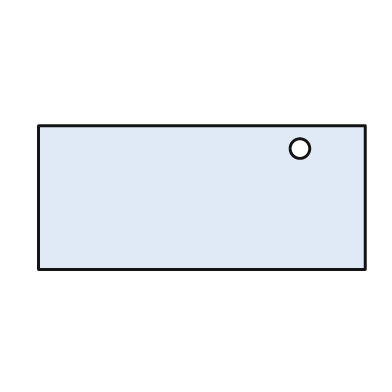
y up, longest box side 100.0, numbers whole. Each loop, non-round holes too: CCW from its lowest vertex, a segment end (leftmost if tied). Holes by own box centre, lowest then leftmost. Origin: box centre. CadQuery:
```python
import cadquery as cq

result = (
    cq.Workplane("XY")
    .moveTo(-50.0, -22.0)
    .lineTo(50.0, -22.0)
    .lineTo(50.0, 22.0)
    .lineTo(-50.0, 22.0)
    .close()
    .moveTo(30.0, 15.0)
    .circle(3.0)
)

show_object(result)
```